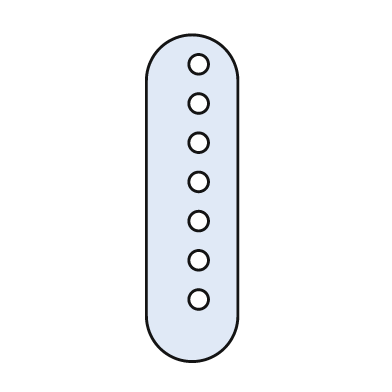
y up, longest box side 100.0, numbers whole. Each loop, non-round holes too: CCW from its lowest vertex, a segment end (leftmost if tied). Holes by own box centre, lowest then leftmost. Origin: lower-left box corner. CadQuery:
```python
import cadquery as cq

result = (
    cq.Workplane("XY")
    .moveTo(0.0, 14.0)
    .threePointArc((14.0, 0.0), (28.0, 14.0))
    .lineTo(28.0, 86.0)
    .threePointArc((14.0, 100.0), (0.0, 86.0))
    .close()
    .moveTo(16.0, 19.0)
    .circle(3.0)
    .moveTo(16.0, 31.0)
    .circle(3.0)
    .moveTo(16.0, 43.0)
    .circle(3.0)
    .moveTo(16.0, 55.0)
    .circle(3.0)
    .moveTo(16.0, 67.0)
    .circle(3.0)
    .moveTo(16.0, 79.0)
    .circle(3.0)
    .moveTo(16.0, 91.0)
    .circle(3.0)
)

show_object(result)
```